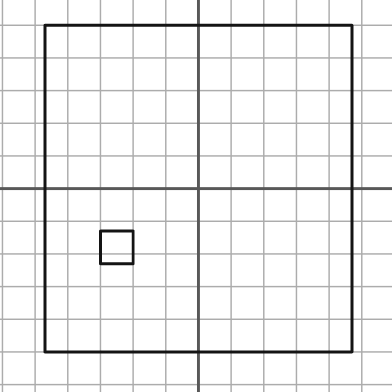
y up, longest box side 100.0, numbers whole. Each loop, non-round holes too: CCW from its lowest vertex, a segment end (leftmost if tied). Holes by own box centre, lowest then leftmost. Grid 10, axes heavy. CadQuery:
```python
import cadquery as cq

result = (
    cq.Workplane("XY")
    .moveTo(-47.0, -50.0)
    .lineTo(47.0, -50.0)
    .lineTo(47.0, 50.0)
    .lineTo(-47.0, 50.0)
    .close()
    .moveTo(-30.0, -23.0)
    .lineTo(-20.0, -23.0)
    .lineTo(-20.0, -13.0)
    .lineTo(-30.0, -13.0)
    .close()
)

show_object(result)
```